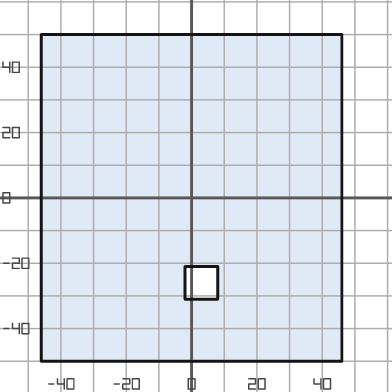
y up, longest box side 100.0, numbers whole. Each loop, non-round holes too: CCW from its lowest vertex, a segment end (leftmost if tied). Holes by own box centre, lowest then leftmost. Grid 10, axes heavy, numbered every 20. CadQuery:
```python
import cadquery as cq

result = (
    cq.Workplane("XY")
    .moveTo(-46.0, -50.0)
    .lineTo(46.0, -50.0)
    .lineTo(46.0, 50.0)
    .lineTo(-46.0, 50.0)
    .close()
    .moveTo(-2.0, -31.0)
    .lineTo(8.0, -31.0)
    .lineTo(8.0, -21.0)
    .lineTo(-2.0, -21.0)
    .close()
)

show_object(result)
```